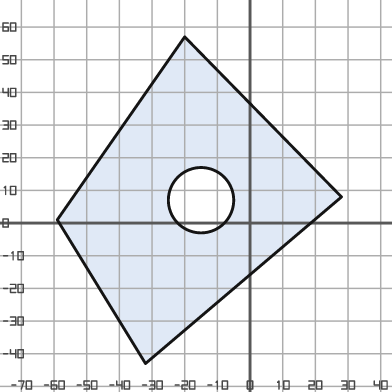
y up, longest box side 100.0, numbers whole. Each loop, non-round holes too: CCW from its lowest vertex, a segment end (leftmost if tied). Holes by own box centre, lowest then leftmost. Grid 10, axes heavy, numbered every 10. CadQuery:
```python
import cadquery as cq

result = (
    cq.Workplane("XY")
    .moveTo(-32.0, -43.0)
    .lineTo(28.0, 8.0)
    .lineTo(-20.0, 57.0)
    .lineTo(-59.0, 1.0)
    .close()
    .moveTo(-15.0, 7.0)
    .circle(10.0)
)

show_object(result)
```